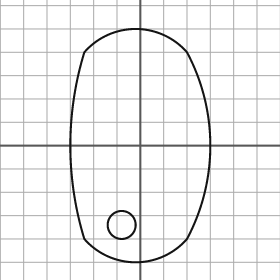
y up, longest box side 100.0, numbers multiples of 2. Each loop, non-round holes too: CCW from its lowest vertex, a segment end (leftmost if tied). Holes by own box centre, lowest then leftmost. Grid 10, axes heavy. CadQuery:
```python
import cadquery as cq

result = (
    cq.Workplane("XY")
    .moveTo(-24.0, -40.0)
    .threePointArc((-2.0, -50.0), (20.0, -40.0))
    .threePointArc((30.0, 0.0), (20.0, 40.0))
    .threePointArc((-2.0, 50.0), (-24.0, 40.0))
    .threePointArc((-30.0, 0.0), (-24.0, -40.0))
    .close()
    .moveTo(-8.0, -34.0)
    .circle(6.0)
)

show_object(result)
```